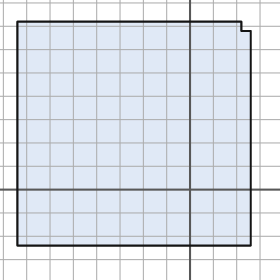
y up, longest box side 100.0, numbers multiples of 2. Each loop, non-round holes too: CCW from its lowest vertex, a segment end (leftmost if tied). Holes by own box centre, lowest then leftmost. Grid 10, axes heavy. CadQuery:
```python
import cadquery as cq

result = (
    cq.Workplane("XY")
    .moveTo(-74.0, -24.0)
    .lineTo(26.0, -24.0)
    .lineTo(26.0, 68.0)
    .lineTo(22.0, 68.0)
    .lineTo(22.0, 72.0)
    .lineTo(-74.0, 72.0)
    .close()
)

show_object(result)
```